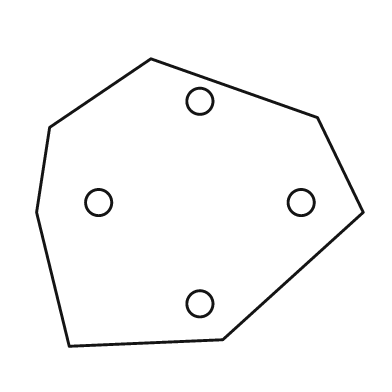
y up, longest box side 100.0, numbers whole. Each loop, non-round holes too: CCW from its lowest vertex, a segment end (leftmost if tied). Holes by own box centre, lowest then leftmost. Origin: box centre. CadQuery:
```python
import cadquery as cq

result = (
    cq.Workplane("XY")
    .moveTo(-40.0, -44.0)
    .lineTo(7.0, -42.0)
    .lineTo(50.0, -3.0)
    .lineTo(36.0, 26.0)
    .lineTo(-15.0, 44.0)
    .lineTo(-46.0, 23.0)
    .lineTo(-50.0, -3.0)
    .close()
    .moveTo(0.0, -31.0)
    .circle(4.0)
    .moveTo(-31.0, 0.0)
    .circle(4.0)
    .moveTo(31.0, 0.0)
    .circle(4.0)
    .moveTo(0.0, 31.0)
    .circle(4.0)
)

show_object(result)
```